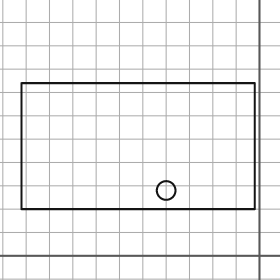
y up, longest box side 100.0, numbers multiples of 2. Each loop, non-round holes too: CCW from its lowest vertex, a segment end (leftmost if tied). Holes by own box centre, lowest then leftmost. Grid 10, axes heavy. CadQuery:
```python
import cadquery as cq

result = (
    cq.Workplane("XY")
    .moveTo(-102.0, 20.0)
    .lineTo(-2.0, 20.0)
    .lineTo(-2.0, 74.0)
    .lineTo(-102.0, 74.0)
    .close()
    .moveTo(-40.0, 28.0)
    .circle(4.0)
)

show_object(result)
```